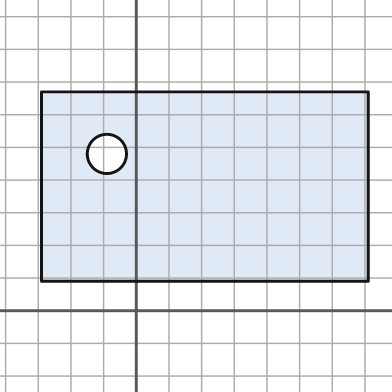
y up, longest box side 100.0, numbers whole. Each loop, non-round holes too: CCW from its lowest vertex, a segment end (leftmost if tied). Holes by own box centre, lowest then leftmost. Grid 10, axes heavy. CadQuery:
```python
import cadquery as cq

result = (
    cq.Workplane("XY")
    .moveTo(-29.0, 9.0)
    .lineTo(71.0, 9.0)
    .lineTo(71.0, 67.0)
    .lineTo(-29.0, 67.0)
    .close()
    .moveTo(-9.0, 48.0)
    .circle(6.0)
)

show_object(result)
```